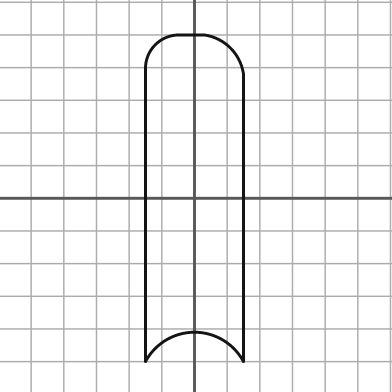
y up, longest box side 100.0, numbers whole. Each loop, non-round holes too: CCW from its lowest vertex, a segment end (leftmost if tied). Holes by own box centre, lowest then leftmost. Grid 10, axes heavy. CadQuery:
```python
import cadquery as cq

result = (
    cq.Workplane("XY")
    .moveTo(-15.0, -50.0)
    .threePointArc((0.0, -41.0), (15.0, -50.0))
    .lineTo(15.0, 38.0)
    .threePointArc((11.0, 46.0), (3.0, 50.0))
    .lineTo(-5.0, 50.0)
    .threePointArc((-12.0, 47.0), (-15.0, 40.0))
    .close()
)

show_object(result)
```